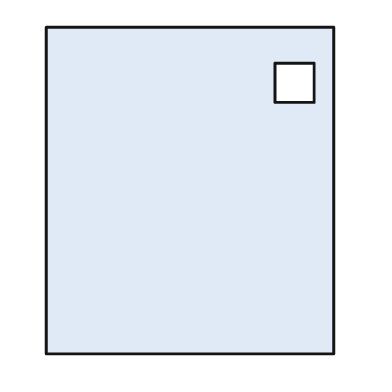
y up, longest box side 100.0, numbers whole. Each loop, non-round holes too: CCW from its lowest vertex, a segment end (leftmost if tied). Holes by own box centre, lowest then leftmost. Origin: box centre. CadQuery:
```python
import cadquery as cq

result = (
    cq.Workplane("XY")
    .moveTo(-44.0, -50.0)
    .lineTo(44.0, -50.0)
    .lineTo(44.0, 50.0)
    .lineTo(-44.0, 50.0)
    .close()
    .moveTo(26.0, 27.0)
    .lineTo(38.0, 27.0)
    .lineTo(38.0, 39.0)
    .lineTo(26.0, 39.0)
    .close()
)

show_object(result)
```